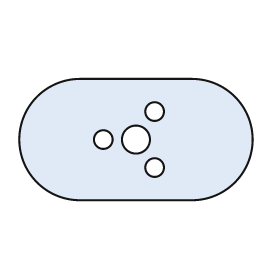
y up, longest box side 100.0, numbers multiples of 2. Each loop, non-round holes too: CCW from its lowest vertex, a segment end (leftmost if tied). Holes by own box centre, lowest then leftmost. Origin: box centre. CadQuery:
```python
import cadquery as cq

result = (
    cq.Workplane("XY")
    .moveTo(-24.0, -26.0)
    .lineTo(24.0, -26.0)
    .threePointArc((50.0, 0.0), (24.0, 26.0))
    .lineTo(-24.0, 26.0)
    .threePointArc((-50.0, 0.0), (-24.0, -26.0))
    .close()
    .moveTo(8.0, -12.0)
    .circle(4.0)
    .moveTo(-14.0, 0.0)
    .circle(4.0)
    .moveTo(0.0, 0.0)
    .circle(6.0)
    .moveTo(8.0, 12.0)
    .circle(4.0)
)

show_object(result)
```